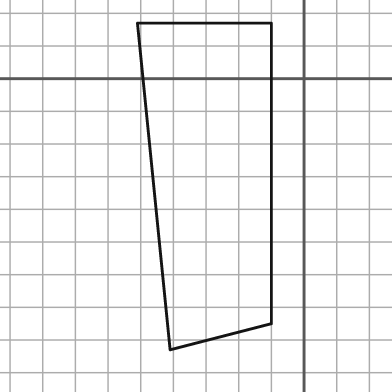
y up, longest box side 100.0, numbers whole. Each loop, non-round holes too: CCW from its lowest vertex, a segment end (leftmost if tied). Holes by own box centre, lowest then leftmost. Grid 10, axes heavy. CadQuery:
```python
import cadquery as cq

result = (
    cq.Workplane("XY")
    .moveTo(-41.0, -83.0)
    .lineTo(-10.0, -75.0)
    .lineTo(-10.0, 17.0)
    .lineTo(-51.0, 17.0)
    .close()
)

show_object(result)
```